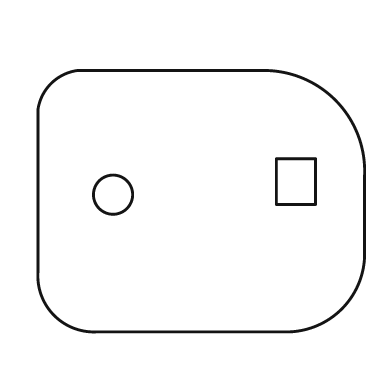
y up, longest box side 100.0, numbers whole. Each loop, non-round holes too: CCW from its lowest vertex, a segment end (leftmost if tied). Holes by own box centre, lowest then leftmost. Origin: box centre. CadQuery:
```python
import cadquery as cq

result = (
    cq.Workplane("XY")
    .moveTo(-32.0, -40.0)
    .lineTo(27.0, -40.0)
    .threePointArc((43.0, -33.0), (50.0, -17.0))
    .lineTo(50.0, 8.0)
    .threePointArc((41.0, 31.0), (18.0, 40.0))
    .lineTo(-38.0, 40.0)
    .threePointArc((-46.0, 36.0), (-50.0, 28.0))
    .lineTo(-50.0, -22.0)
    .threePointArc((-45.0, -35.0), (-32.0, -40.0))
    .close()
    .moveTo(-27.0, 2.0)
    .circle(6.0)
    .moveTo(23.0, -1.0)
    .lineTo(35.0, -1.0)
    .lineTo(35.0, 13.0)
    .lineTo(23.0, 13.0)
    .close()
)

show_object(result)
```